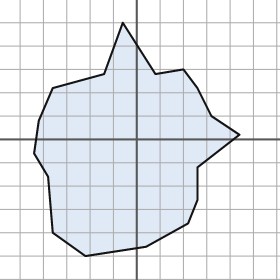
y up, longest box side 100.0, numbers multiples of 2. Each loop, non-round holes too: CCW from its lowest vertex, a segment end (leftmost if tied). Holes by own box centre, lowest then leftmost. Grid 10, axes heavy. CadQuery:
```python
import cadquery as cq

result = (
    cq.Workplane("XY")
    .moveTo(-22.0, -50.0)
    .lineTo(4.0, -46.0)
    .lineTo(22.0, -36.0)
    .lineTo(26.0, -26.0)
    .lineTo(26.0, -12.0)
    .lineTo(44.0, 2.0)
    .lineTo(32.0, 10.0)
    .lineTo(26.0, 22.0)
    .lineTo(20.0, 30.0)
    .lineTo(8.0, 28.0)
    .lineTo(-6.0, 50.0)
    .lineTo(-14.0, 28.0)
    .lineTo(-36.0, 22.0)
    .lineTo(-42.0, 8.0)
    .lineTo(-44.0, -6.0)
    .lineTo(-38.0, -16.0)
    .lineTo(-36.0, -40.0)
    .close()
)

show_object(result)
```